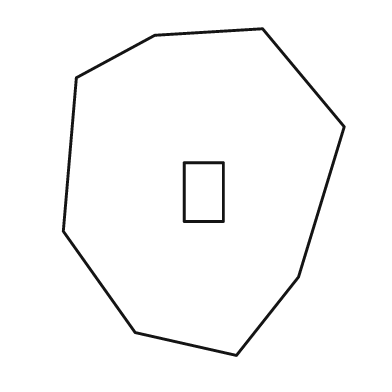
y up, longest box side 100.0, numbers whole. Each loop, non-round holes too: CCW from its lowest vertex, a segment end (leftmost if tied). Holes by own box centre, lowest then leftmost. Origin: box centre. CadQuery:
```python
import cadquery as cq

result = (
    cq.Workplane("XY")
    .moveTo(10.0, -50.0)
    .lineTo(29.0, -26.0)
    .lineTo(43.0, 20.0)
    .lineTo(18.0, 50.0)
    .lineTo(-15.0, 48.0)
    .lineTo(-39.0, 35.0)
    .lineTo(-43.0, -12.0)
    .lineTo(-21.0, -43.0)
    .close()
    .moveTo(-6.0, -9.0)
    .lineTo(6.0, -9.0)
    .lineTo(6.0, 9.0)
    .lineTo(-6.0, 9.0)
    .close()
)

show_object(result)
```